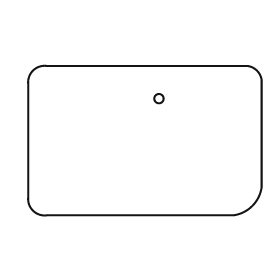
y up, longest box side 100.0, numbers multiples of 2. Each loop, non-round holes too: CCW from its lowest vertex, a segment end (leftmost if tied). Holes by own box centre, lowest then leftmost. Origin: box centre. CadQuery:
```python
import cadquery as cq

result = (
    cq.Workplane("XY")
    .moveTo(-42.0, -32.0)
    .lineTo(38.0, -32.0)
    .threePointArc((46.0, -28.0), (50.0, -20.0))
    .lineTo(50.0, 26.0)
    .threePointArc((48.0, 30.0), (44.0, 32.0))
    .lineTo(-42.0, 32.0)
    .threePointArc((-48.0, 30.0), (-50.0, 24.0))
    .lineTo(-50.0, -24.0)
    .threePointArc((-48.0, -30.0), (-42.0, -32.0))
    .close()
    .moveTo(6.0, 18.0)
    .circle(2.0)
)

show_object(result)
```